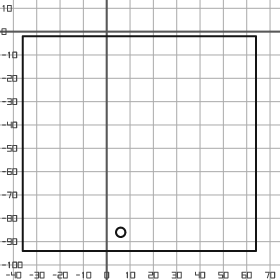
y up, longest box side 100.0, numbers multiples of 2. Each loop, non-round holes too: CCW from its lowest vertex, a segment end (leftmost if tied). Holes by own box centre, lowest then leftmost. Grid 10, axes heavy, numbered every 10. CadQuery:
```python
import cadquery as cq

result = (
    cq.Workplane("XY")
    .moveTo(-36.0, -94.0)
    .lineTo(64.0, -94.0)
    .lineTo(64.0, -2.0)
    .lineTo(-36.0, -2.0)
    .close()
    .moveTo(6.0, -86.0)
    .circle(2.0)
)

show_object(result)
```